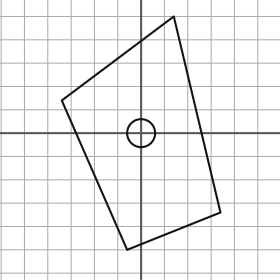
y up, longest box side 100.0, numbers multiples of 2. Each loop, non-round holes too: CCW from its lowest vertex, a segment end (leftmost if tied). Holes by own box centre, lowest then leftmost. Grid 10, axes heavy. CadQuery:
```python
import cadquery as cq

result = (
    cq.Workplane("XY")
    .moveTo(-6.0, -50.0)
    .lineTo(34.0, -34.0)
    .lineTo(14.0, 50.0)
    .lineTo(-34.0, 14.0)
    .close()
    .moveTo(0.0, 0.0)
    .circle(6.0)
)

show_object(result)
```